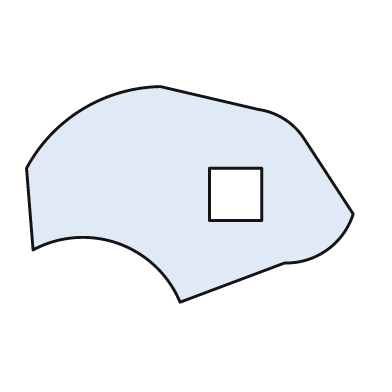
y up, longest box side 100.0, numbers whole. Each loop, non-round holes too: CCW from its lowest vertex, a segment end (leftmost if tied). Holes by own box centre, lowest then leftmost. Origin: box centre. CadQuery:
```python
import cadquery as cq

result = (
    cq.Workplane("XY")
    .moveTo(-3.0, -33.0)
    .lineTo(29.0, -21.0)
    .threePointArc((42.0, -17.0), (50.0, -6.0))
    .lineTo(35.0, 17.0)
    .threePointArc((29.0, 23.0), (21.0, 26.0))
    .lineTo(-9.0, 33.0)
    .threePointArc((-33.0, 26.0), (-50.0, 8.0))
    .lineTo(-48.0, -17.0)
    .threePointArc((-22.0, -15.0), (-3.0, -33.0))
    .close()
    .moveTo(6.0, -8.0)
    .lineTo(22.0, -8.0)
    .lineTo(22.0, 8.0)
    .lineTo(6.0, 8.0)
    .close()
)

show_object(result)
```